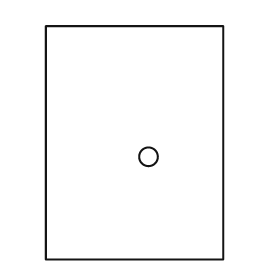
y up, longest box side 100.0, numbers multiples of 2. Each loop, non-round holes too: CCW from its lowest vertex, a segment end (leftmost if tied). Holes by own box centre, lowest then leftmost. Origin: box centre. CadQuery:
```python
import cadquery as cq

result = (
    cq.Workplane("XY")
    .moveTo(-38.0, -50.0)
    .lineTo(38.0, -50.0)
    .lineTo(38.0, 50.0)
    .lineTo(-38.0, 50.0)
    .close()
    .moveTo(6.0, -6.0)
    .circle(4.0)
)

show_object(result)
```